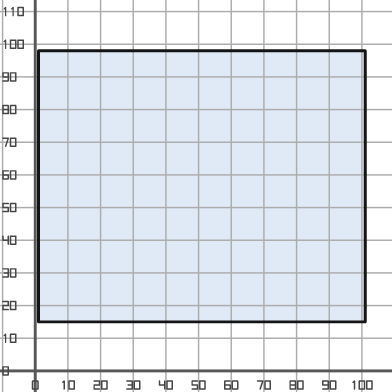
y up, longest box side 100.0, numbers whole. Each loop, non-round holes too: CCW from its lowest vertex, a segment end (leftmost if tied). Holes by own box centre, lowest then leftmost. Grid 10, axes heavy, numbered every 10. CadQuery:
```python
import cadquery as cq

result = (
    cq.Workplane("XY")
    .moveTo(1.0, 15.0)
    .lineTo(101.0, 15.0)
    .lineTo(101.0, 98.0)
    .lineTo(1.0, 98.0)
    .close()
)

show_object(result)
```